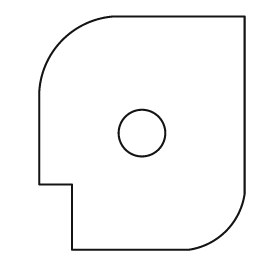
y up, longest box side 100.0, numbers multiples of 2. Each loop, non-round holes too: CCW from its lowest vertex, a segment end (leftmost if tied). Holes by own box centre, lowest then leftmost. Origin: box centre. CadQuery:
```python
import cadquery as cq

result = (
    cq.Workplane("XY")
    .moveTo(-30.0, -50.0)
    .lineTo(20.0, -50.0)
    .threePointArc((36.0, -42.0), (44.0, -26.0))
    .lineTo(44.0, 50.0)
    .lineTo(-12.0, 50.0)
    .threePointArc((-34.0, 40.0), (-44.0, 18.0))
    .lineTo(-44.0, -22.0)
    .lineTo(-30.0, -22.0)
    .close()
    .moveTo(0.0, 0.0)
    .circle(10.0)
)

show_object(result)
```